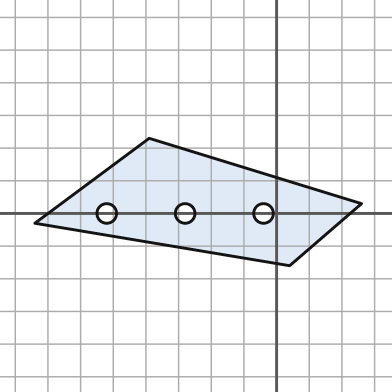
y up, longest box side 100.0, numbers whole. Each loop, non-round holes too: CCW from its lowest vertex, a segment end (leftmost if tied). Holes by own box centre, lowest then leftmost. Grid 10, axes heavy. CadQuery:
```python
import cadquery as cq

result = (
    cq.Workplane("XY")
    .moveTo(4.0, -16.0)
    .lineTo(26.0, 3.0)
    .lineTo(-39.0, 23.0)
    .lineTo(-74.0, -3.0)
    .close()
    .moveTo(-52.0, 0.0)
    .circle(3.0)
    .moveTo(-28.0, 0.0)
    .circle(3.0)
    .moveTo(-4.0, 0.0)
    .circle(3.0)
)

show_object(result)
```